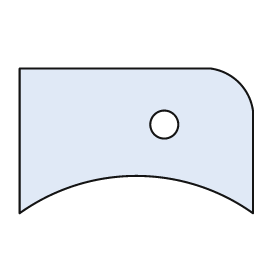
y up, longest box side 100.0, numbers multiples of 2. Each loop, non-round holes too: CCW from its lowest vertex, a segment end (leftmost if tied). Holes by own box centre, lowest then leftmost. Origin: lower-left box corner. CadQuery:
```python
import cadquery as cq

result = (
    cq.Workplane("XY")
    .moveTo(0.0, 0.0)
    .threePointArc((50.0, 16.0), (100.0, 0.0))
    .lineTo(100.0, 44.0)
    .threePointArc((94.0, 56.0), (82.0, 62.0))
    .lineTo(0.0, 62.0)
    .close()
    .moveTo(62.0, 38.0)
    .circle(6.0)
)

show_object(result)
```